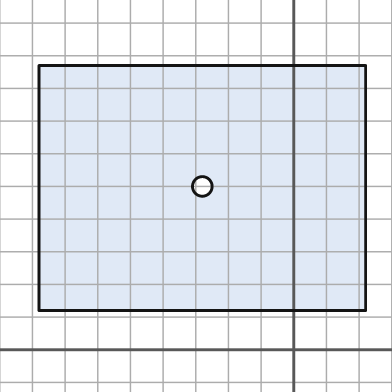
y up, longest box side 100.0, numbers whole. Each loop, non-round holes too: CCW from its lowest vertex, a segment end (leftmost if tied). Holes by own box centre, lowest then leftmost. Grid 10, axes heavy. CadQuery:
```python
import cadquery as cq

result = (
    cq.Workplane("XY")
    .moveTo(-78.0, 12.0)
    .lineTo(22.0, 12.0)
    .lineTo(22.0, 87.0)
    .lineTo(-78.0, 87.0)
    .close()
    .moveTo(-28.0, 50.0)
    .circle(3.0)
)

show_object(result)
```